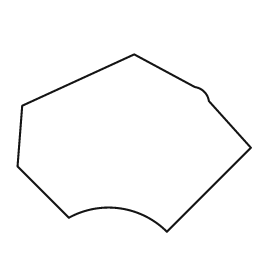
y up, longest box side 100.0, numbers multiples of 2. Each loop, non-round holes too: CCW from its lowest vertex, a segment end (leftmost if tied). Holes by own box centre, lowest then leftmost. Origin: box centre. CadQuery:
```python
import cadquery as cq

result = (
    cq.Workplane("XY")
    .moveTo(14.0, -38.0)
    .lineTo(50.0, -2.0)
    .lineTo(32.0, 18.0)
    .threePointArc((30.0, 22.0), (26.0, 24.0))
    .lineTo(0.0, 38.0)
    .lineTo(-48.0, 16.0)
    .lineTo(-50.0, -10.0)
    .lineTo(-28.0, -32.0)
    .threePointArc((-6.0, -28.0), (14.0, -38.0))
    .close()
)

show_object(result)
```